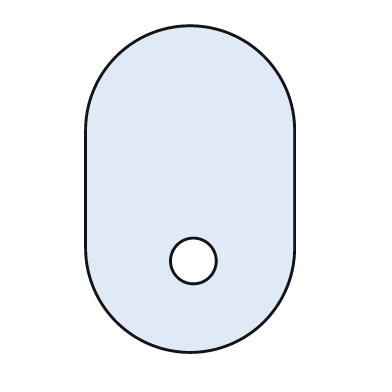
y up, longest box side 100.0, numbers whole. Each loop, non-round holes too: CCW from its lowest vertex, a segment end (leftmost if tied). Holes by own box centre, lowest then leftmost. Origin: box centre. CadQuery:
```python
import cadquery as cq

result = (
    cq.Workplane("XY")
    .moveTo(-32.0, -18.0)
    .threePointArc((0.0, -50.0), (32.0, -18.0))
    .lineTo(32.0, 18.0)
    .threePointArc((0.0, 50.0), (-32.0, 18.0))
    .close()
    .moveTo(1.0, -22.0)
    .circle(7.0)
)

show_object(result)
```